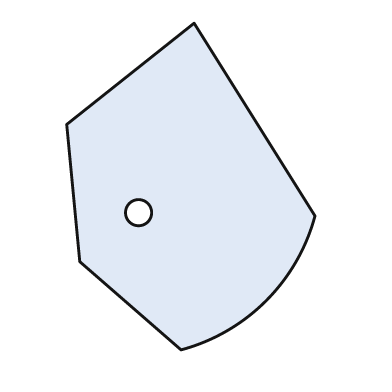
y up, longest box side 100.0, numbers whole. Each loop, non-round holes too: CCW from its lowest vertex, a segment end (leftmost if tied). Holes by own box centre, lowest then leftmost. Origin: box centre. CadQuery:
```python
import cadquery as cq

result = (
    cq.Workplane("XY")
    .moveTo(-3.0, -50.0)
    .threePointArc((23.0, -35.0), (38.0, -9.0))
    .lineTo(1.0, 50.0)
    .lineTo(-38.0, 19.0)
    .lineTo(-34.0, -23.0)
    .close()
    .moveTo(-16.0, -8.0)
    .circle(4.0)
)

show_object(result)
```